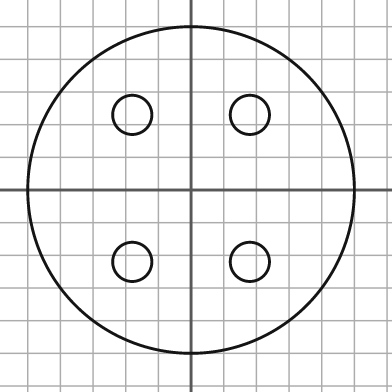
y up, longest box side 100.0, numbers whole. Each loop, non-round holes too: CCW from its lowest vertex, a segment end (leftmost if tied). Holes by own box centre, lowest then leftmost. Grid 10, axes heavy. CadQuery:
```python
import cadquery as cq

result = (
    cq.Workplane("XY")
    .moveTo(0.0, 0.0)
    .circle(50.0)
    .moveTo(-18.0, -22.0)
    .circle(6.0)
    .moveTo(18.0, -22.0)
    .circle(6.0)
    .moveTo(-18.0, 23.0)
    .circle(6.0)
    .moveTo(18.0, 23.0)
    .circle(6.0)
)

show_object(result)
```